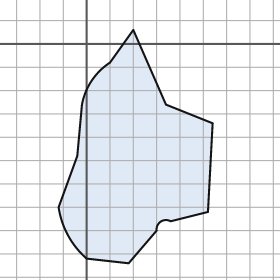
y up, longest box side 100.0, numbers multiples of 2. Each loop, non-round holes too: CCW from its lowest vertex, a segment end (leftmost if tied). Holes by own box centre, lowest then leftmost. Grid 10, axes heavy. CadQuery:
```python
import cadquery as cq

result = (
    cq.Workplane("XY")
    .moveTo(18.0, -94.0)
    .lineTo(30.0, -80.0)
    .threePointArc((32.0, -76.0), (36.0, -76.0))
    .lineTo(52.0, -72.0)
    .lineTo(54.0, -34.0)
    .lineTo(34.0, -26.0)
    .lineTo(20.0, 6.0)
    .lineTo(10.0, -8.0)
    .threePointArc((2.0, -16.0), (-2.0, -26.0))
    .lineTo(-4.0, -48.0)
    .lineTo(-12.0, -70.0)
    .threePointArc((-8.0, -82.0), (0.0, -92.0))
    .close()
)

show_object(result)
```